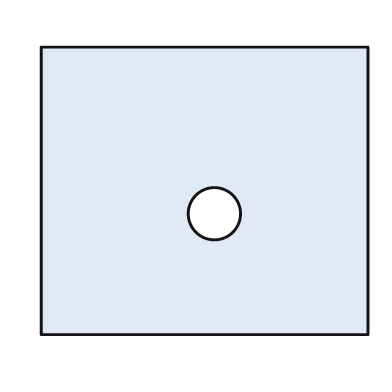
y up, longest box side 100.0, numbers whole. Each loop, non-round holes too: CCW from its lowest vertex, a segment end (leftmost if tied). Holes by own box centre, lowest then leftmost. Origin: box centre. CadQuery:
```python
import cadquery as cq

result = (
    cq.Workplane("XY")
    .moveTo(-50.0, -44.0)
    .lineTo(50.0, -44.0)
    .lineTo(50.0, 44.0)
    .lineTo(-50.0, 44.0)
    .close()
    .moveTo(3.0, -7.0)
    .circle(8.0)
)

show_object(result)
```